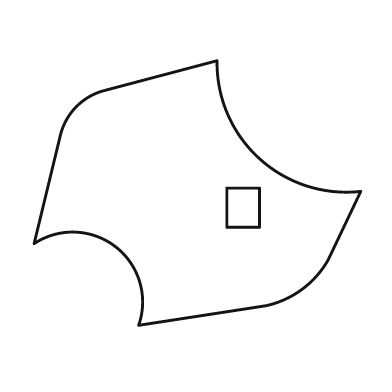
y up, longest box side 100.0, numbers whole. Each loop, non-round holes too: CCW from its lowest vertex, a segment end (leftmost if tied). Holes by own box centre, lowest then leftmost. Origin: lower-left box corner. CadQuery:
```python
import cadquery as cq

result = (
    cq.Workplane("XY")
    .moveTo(32.0, 0.0)
    .lineTo(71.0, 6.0)
    .threePointArc((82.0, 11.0), (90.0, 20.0))
    .lineTo(100.0, 41.0)
    .threePointArc((69.0, 51.0), (56.0, 81.0))
    .lineTo(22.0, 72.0)
    .threePointArc((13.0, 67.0), (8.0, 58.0))
    .lineTo(0.0, 25.0)
    .threePointArc((25.0, 24.0), (32.0, 0.0))
    .close()
    .moveTo(59.0, 30.0)
    .lineTo(69.0, 30.0)
    .lineTo(69.0, 42.0)
    .lineTo(59.0, 42.0)
    .close()
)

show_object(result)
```